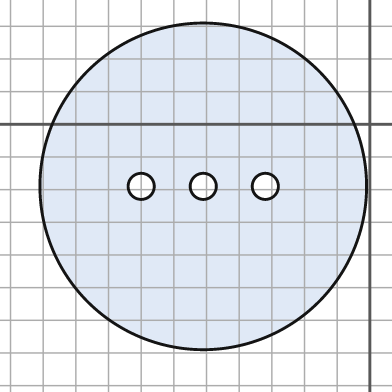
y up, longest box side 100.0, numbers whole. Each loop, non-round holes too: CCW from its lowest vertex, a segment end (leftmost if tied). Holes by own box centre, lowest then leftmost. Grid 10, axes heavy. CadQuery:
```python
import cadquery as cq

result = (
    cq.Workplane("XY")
    .moveTo(-51.0, -19.0)
    .circle(50.0)
    .moveTo(-70.0, -19.0)
    .circle(4.0)
    .moveTo(-51.0, -19.0)
    .circle(4.0)
    .moveTo(-32.0, -19.0)
    .circle(4.0)
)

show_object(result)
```